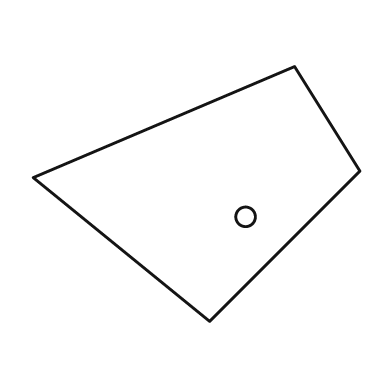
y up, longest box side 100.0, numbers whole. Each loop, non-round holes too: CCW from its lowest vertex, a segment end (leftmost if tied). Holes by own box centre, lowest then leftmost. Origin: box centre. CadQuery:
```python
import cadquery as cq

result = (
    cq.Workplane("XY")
    .moveTo(4.0, -39.0)
    .lineTo(50.0, 7.0)
    .lineTo(30.0, 39.0)
    .lineTo(-50.0, 5.0)
    .close()
    .moveTo(15.0, -7.0)
    .circle(3.0)
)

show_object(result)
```